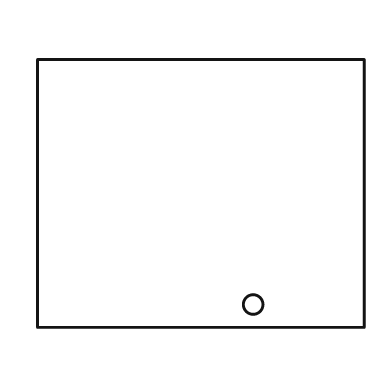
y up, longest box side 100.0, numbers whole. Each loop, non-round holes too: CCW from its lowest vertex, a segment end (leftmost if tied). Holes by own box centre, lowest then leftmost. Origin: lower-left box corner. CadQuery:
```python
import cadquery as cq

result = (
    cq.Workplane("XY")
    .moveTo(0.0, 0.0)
    .lineTo(100.0, 0.0)
    .lineTo(100.0, 82.0)
    .lineTo(0.0, 82.0)
    .close()
    .moveTo(66.0, 7.0)
    .circle(3.0)
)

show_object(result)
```